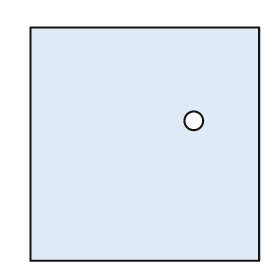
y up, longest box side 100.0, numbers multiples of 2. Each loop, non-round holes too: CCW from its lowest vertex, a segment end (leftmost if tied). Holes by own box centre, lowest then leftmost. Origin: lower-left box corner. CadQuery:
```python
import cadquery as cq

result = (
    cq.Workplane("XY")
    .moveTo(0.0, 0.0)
    .lineTo(98.0, 0.0)
    .lineTo(98.0, 100.0)
    .lineTo(0.0, 100.0)
    .close()
    .moveTo(70.0, 60.0)
    .circle(4.0)
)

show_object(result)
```